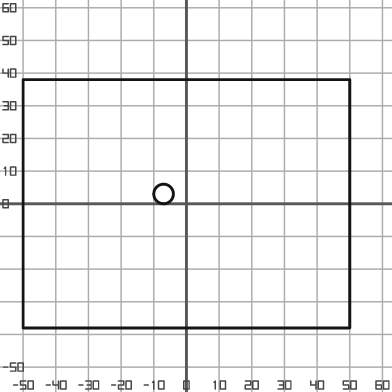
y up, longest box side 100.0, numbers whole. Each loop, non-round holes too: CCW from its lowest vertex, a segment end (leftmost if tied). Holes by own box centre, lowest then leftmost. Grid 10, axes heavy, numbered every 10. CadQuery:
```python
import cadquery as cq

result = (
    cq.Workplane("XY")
    .moveTo(-50.0, -38.0)
    .lineTo(50.0, -38.0)
    .lineTo(50.0, 38.0)
    .lineTo(-50.0, 38.0)
    .close()
    .moveTo(-7.0, 3.0)
    .circle(3.0)
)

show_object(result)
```